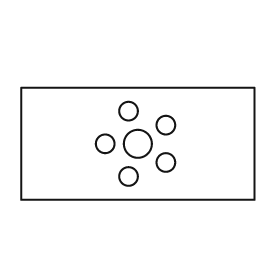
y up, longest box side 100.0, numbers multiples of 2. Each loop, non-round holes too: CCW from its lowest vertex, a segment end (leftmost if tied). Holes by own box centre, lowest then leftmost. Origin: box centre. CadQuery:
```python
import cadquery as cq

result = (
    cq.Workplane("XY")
    .moveTo(-50.0, -24.0)
    .lineTo(50.0, -24.0)
    .lineTo(50.0, 24.0)
    .lineTo(-50.0, 24.0)
    .close()
    .moveTo(-4.0, -14.0)
    .circle(4.0)
    .moveTo(12.0, -8.0)
    .circle(4.0)
    .moveTo(-14.0, 0.0)
    .circle(4.0)
    .moveTo(0.0, 0.0)
    .circle(6.0)
    .moveTo(12.0, 8.0)
    .circle(4.0)
    .moveTo(-4.0, 14.0)
    .circle(4.0)
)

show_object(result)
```